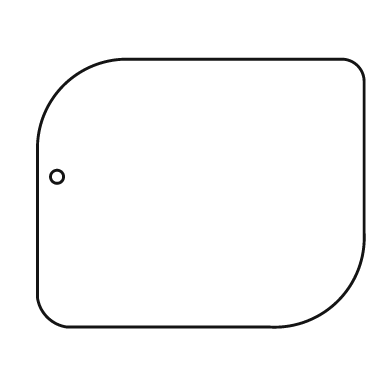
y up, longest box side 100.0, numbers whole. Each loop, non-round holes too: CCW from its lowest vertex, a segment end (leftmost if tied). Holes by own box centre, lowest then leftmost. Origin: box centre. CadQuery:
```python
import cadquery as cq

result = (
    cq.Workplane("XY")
    .moveTo(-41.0, -41.0)
    .lineTo(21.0, -41.0)
    .threePointArc((42.0, -33.0), (50.0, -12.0))
    .lineTo(50.0, 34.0)
    .threePointArc((48.0, 39.0), (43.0, 41.0))
    .lineTo(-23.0, 41.0)
    .threePointArc((-42.0, 33.0), (-50.0, 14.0))
    .lineTo(-50.0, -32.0)
    .threePointArc((-47.0, -38.0), (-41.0, -41.0))
    .close()
    .moveTo(-44.0, 5.0)
    .circle(2.0)
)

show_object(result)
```